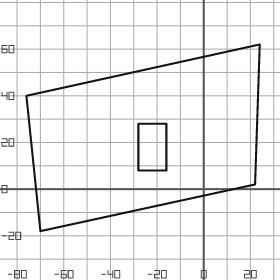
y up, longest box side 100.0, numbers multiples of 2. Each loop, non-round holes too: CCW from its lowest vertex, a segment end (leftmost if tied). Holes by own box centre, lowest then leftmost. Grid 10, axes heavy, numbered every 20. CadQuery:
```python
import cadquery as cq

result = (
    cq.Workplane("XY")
    .moveTo(-70.0, -18.0)
    .lineTo(22.0, 2.0)
    .lineTo(24.0, 62.0)
    .lineTo(-76.0, 40.0)
    .close()
    .moveTo(-28.0, 8.0)
    .lineTo(-16.0, 8.0)
    .lineTo(-16.0, 28.0)
    .lineTo(-28.0, 28.0)
    .close()
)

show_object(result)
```